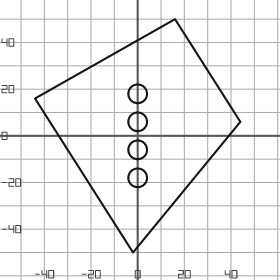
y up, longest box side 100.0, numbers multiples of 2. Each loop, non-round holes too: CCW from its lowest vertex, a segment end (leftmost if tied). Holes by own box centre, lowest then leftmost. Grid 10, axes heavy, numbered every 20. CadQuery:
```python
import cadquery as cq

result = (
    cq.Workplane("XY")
    .moveTo(-2.0, -50.0)
    .lineTo(44.0, 6.0)
    .lineTo(16.0, 50.0)
    .lineTo(-44.0, 16.0)
    .close()
    .moveTo(0.0, -18.0)
    .circle(4.0)
    .moveTo(0.0, -6.0)
    .circle(4.0)
    .moveTo(0.0, 6.0)
    .circle(4.0)
    .moveTo(0.0, 18.0)
    .circle(4.0)
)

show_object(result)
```